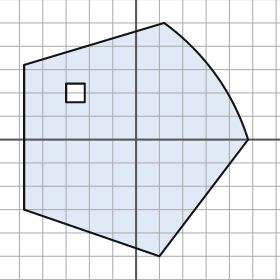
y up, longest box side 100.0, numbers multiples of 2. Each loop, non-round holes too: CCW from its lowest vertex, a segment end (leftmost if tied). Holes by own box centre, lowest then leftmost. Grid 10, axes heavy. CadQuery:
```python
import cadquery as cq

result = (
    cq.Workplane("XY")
    .moveTo(10.0, -50.0)
    .lineTo(48.0, 0.0)
    .threePointArc((34.0, 28.0), (12.0, 50.0))
    .lineTo(-48.0, 32.0)
    .lineTo(-48.0, -30.0)
    .close()
    .moveTo(-30.0, 16.0)
    .lineTo(-22.0, 16.0)
    .lineTo(-22.0, 24.0)
    .lineTo(-30.0, 24.0)
    .close()
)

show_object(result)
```